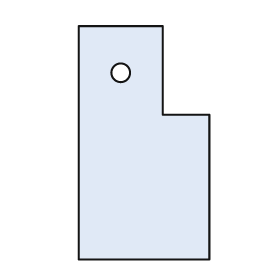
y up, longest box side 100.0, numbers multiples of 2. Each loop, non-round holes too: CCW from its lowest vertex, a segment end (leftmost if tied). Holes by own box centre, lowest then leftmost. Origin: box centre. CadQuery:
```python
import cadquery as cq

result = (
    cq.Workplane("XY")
    .moveTo(-28.0, -50.0)
    .lineTo(28.0, -50.0)
    .lineTo(28.0, 12.0)
    .lineTo(8.0, 12.0)
    .lineTo(8.0, 50.0)
    .lineTo(-28.0, 50.0)
    .close()
    .moveTo(-10.0, 30.0)
    .circle(4.0)
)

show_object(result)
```